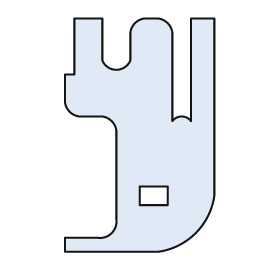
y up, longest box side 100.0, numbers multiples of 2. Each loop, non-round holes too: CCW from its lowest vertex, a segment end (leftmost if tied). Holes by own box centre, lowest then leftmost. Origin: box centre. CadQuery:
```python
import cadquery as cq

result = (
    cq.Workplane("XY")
    .moveTo(-32.0, -50.0)
    .lineTo(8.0, -50.0)
    .threePointArc((24.0, -42.0), (32.0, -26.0))
    .lineTo(32.0, 50.0)
    .lineTo(22.0, 50.0)
    .lineTo(22.0, 6.0)
    .threePointArc((18.0, 8.0), (14.0, 6.0))
    .lineTo(14.0, 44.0)
    .threePointArc((12.0, 48.0), (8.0, 50.0))
    .lineTo(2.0, 50.0)
    .threePointArc((-2.0, 48.0), (-4.0, 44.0))
    .lineTo(-4.0, 32.0)
    .threePointArc((-10.0, 28.0), (-16.0, 32.0))
    .lineTo(-16.0, 50.0)
    .lineTo(-28.0, 50.0)
    .lineTo(-28.0, 26.0)
    .lineTo(-32.0, 26.0)
    .lineTo(-32.0, 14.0)
    .threePointArc((-30.0, 10.0), (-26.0, 8.0))
    .lineTo(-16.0, 8.0)
    .threePointArc((-12.0, 6.0), (-10.0, 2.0))
    .lineTo(-10.0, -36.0)
    .threePointArc((-12.0, -42.0), (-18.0, -44.0))
    .lineTo(-32.0, -44.0)
    .close()
    .moveTo(0.0, -30.0)
    .lineTo(12.0, -30.0)
    .lineTo(12.0, -22.0)
    .lineTo(0.0, -22.0)
    .close()
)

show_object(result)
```